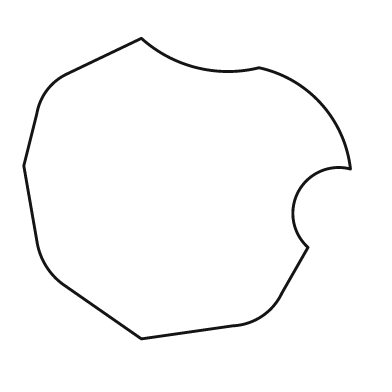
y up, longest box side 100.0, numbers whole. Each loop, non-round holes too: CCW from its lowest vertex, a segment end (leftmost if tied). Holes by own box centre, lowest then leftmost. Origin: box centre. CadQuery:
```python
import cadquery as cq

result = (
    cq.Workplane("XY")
    .moveTo(-14.0, -46.0)
    .lineTo(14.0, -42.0)
    .threePointArc((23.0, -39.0), (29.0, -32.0))
    .lineTo(37.0, -18.0)
    .threePointArc((34.0, -1.0), (50.0, 6.0))
    .threePointArc((41.0, 26.0), (22.0, 37.0))
    .threePointArc((3.0, 37.0), (-14.0, 46.0))
    .lineTo(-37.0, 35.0)
    .threePointArc((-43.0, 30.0), (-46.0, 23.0))
    .lineTo(-50.0, 7.0)
    .lineTo(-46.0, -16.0)
    .threePointArc((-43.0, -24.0), (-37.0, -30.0))
    .close()
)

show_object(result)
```